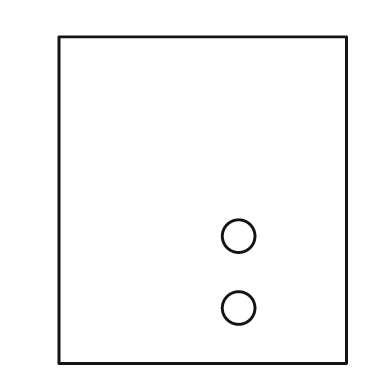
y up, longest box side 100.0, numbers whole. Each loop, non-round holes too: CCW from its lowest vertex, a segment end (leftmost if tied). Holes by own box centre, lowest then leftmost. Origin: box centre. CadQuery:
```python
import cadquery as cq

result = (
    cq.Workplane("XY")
    .moveTo(-44.0, -50.0)
    .lineTo(44.0, -50.0)
    .lineTo(44.0, 50.0)
    .lineTo(-44.0, 50.0)
    .close()
    .moveTo(11.0, -33.0)
    .circle(5.0)
    .moveTo(11.0, -11.0)
    .circle(5.0)
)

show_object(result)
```